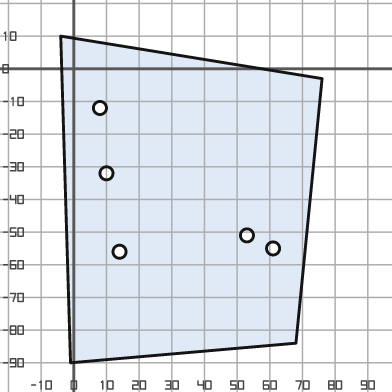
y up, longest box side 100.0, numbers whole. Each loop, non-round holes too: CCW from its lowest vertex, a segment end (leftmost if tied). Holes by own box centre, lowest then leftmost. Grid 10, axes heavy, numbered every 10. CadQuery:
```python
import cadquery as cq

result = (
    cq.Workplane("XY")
    .moveTo(-1.0, -90.0)
    .lineTo(68.0, -84.0)
    .lineTo(76.0, -3.0)
    .lineTo(-4.0, 10.0)
    .close()
    .moveTo(14.0, -56.0)
    .circle(2.0)
    .moveTo(61.0, -55.0)
    .circle(2.0)
    .moveTo(53.0, -51.0)
    .circle(2.0)
    .moveTo(10.0, -32.0)
    .circle(2.0)
    .moveTo(8.0, -12.0)
    .circle(2.0)
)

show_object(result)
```